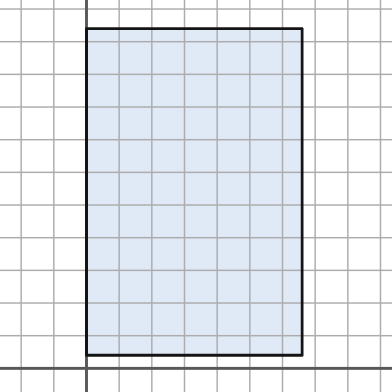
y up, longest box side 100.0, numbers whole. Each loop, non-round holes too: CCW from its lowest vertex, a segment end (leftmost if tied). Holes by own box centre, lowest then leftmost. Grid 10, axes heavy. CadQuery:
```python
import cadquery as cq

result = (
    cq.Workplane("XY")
    .moveTo(0.0, 4.0)
    .lineTo(66.0, 4.0)
    .lineTo(66.0, 104.0)
    .lineTo(0.0, 104.0)
    .close()
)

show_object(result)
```